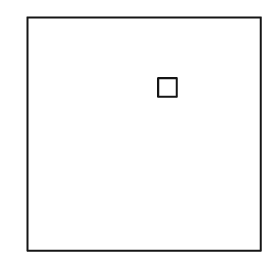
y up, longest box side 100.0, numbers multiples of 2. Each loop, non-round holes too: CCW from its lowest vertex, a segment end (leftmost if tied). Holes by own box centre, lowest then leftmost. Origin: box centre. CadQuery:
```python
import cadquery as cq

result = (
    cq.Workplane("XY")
    .moveTo(-50.0, -50.0)
    .lineTo(50.0, -50.0)
    .lineTo(50.0, 50.0)
    .lineTo(-50.0, 50.0)
    .close()
    .moveTo(6.0, 16.0)
    .lineTo(14.0, 16.0)
    .lineTo(14.0, 24.0)
    .lineTo(6.0, 24.0)
    .close()
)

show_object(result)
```